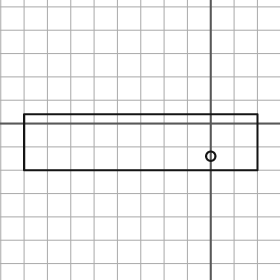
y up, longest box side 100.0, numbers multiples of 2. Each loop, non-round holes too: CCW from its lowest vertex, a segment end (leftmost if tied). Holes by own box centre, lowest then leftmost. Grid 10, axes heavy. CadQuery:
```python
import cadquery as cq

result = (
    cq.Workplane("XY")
    .moveTo(-80.0, -20.0)
    .lineTo(20.0, -20.0)
    .lineTo(20.0, 4.0)
    .lineTo(-80.0, 4.0)
    .close()
    .moveTo(0.0, -14.0)
    .circle(2.0)
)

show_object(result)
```